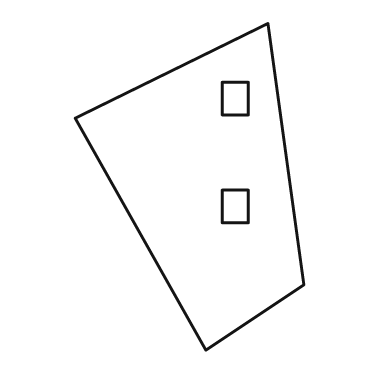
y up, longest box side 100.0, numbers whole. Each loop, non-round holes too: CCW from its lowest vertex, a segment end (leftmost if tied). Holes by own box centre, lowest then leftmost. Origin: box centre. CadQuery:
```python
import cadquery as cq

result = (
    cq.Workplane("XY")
    .moveTo(5.0, -50.0)
    .lineTo(35.0, -30.0)
    .lineTo(24.0, 50.0)
    .lineTo(-35.0, 21.0)
    .close()
    .moveTo(10.0, -11.0)
    .lineTo(18.0, -11.0)
    .lineTo(18.0, -1.0)
    .lineTo(10.0, -1.0)
    .close()
    .moveTo(10.0, 22.0)
    .lineTo(18.0, 22.0)
    .lineTo(18.0, 32.0)
    .lineTo(10.0, 32.0)
    .close()
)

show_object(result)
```